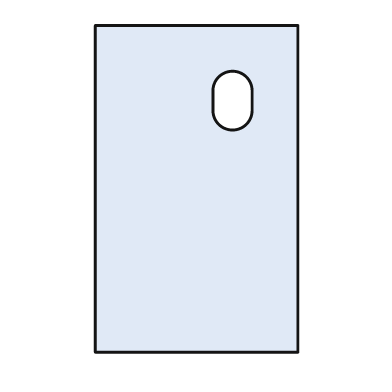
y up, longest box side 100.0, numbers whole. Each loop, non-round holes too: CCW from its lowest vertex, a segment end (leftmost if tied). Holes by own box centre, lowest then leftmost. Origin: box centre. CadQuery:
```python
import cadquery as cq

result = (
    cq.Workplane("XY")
    .moveTo(-31.0, -50.0)
    .lineTo(31.0, -50.0)
    .lineTo(31.0, 50.0)
    .lineTo(-31.0, 50.0)
    .close()
    .moveTo(5.0, 24.0)
    .threePointArc((11.0, 18.0), (17.0, 24.0))
    .lineTo(17.0, 30.0)
    .threePointArc((11.0, 36.0), (5.0, 30.0))
    .close()
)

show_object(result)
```